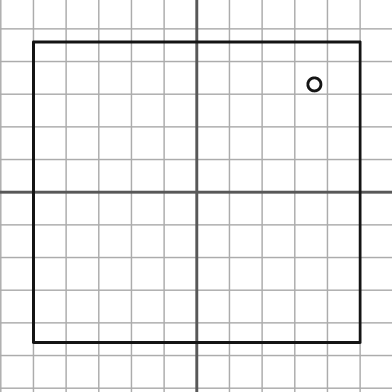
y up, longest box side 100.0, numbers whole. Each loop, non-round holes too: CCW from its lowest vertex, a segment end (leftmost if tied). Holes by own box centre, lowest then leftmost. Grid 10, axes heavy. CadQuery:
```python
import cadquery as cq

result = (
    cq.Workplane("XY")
    .moveTo(-50.0, -46.0)
    .lineTo(50.0, -46.0)
    .lineTo(50.0, 46.0)
    .lineTo(-50.0, 46.0)
    .close()
    .moveTo(36.0, 33.0)
    .circle(2.0)
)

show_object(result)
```